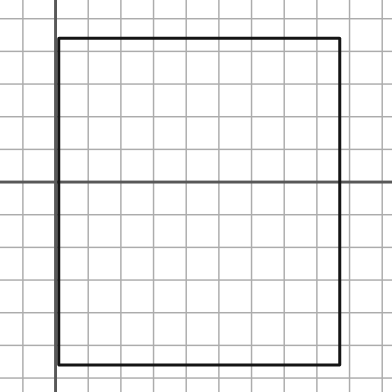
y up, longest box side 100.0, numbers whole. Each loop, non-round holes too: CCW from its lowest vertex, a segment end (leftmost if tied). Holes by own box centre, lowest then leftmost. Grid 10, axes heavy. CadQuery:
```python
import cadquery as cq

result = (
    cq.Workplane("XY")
    .moveTo(1.0, -56.0)
    .lineTo(87.0, -56.0)
    .lineTo(87.0, 44.0)
    .lineTo(1.0, 44.0)
    .close()
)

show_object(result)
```